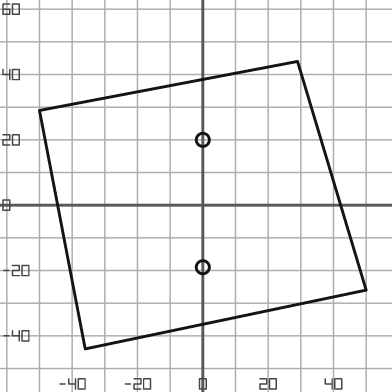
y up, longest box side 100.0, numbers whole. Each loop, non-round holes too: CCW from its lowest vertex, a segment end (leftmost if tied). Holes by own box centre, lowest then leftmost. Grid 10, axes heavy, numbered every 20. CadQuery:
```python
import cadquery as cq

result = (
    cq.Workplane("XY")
    .moveTo(-36.0, -44.0)
    .lineTo(50.0, -26.0)
    .lineTo(29.0, 44.0)
    .lineTo(-50.0, 29.0)
    .close()
    .moveTo(0.0, -19.0)
    .circle(2.0)
    .moveTo(0.0, 20.0)
    .circle(2.0)
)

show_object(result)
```